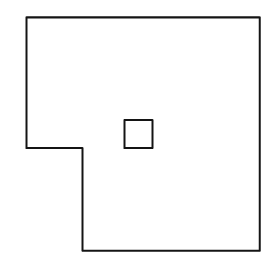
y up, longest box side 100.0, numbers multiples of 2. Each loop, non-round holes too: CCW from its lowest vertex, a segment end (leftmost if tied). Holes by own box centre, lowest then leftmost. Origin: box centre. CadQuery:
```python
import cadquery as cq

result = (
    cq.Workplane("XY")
    .moveTo(-26.0, -50.0)
    .lineTo(50.0, -50.0)
    .lineTo(50.0, 50.0)
    .lineTo(-50.0, 50.0)
    .lineTo(-50.0, -6.0)
    .lineTo(-26.0, -6.0)
    .close()
    .moveTo(-8.0, -6.0)
    .lineTo(4.0, -6.0)
    .lineTo(4.0, 6.0)
    .lineTo(-8.0, 6.0)
    .close()
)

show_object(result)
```